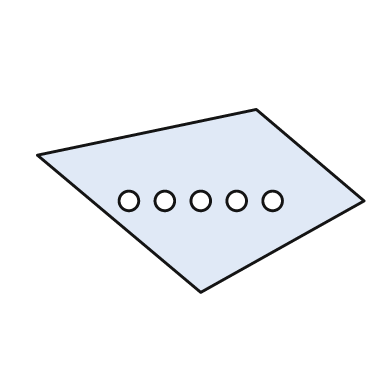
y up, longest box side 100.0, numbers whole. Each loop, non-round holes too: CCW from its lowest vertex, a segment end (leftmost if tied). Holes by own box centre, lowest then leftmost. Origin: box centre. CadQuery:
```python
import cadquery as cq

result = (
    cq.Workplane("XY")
    .moveTo(0.0, -28.0)
    .lineTo(50.0, 0.0)
    .lineTo(17.0, 28.0)
    .lineTo(-50.0, 14.0)
    .close()
    .moveTo(-22.0, 0.0)
    .circle(3.0)
    .moveTo(-11.0, 0.0)
    .circle(3.0)
    .moveTo(0.0, 0.0)
    .circle(3.0)
    .moveTo(11.0, 0.0)
    .circle(3.0)
    .moveTo(22.0, 0.0)
    .circle(3.0)
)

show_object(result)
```